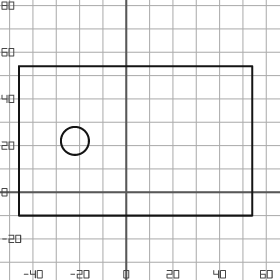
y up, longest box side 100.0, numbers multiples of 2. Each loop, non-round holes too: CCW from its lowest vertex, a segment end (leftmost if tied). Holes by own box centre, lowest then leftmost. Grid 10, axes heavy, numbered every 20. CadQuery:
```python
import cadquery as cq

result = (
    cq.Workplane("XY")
    .moveTo(-46.0, -10.0)
    .lineTo(54.0, -10.0)
    .lineTo(54.0, 54.0)
    .lineTo(-46.0, 54.0)
    .close()
    .moveTo(-22.0, 22.0)
    .circle(6.0)
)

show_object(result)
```